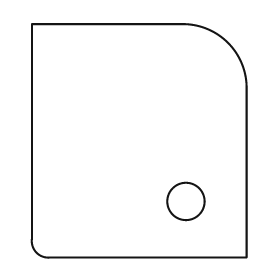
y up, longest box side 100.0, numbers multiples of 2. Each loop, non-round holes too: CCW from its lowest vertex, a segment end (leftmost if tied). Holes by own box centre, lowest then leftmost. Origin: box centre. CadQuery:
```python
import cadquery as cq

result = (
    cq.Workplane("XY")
    .moveTo(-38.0, -50.0)
    .lineTo(46.0, -50.0)
    .lineTo(46.0, 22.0)
    .threePointArc((38.0, 42.0), (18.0, 50.0))
    .lineTo(-46.0, 50.0)
    .lineTo(-46.0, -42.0)
    .threePointArc((-44.0, -48.0), (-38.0, -50.0))
    .close()
    .moveTo(20.0, -26.0)
    .circle(8.0)
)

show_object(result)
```